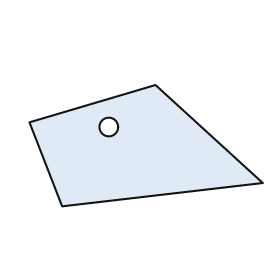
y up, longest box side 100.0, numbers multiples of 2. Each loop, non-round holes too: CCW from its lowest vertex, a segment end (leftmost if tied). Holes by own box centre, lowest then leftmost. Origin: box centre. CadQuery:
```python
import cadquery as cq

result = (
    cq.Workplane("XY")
    .moveTo(-36.0, -26.0)
    .lineTo(50.0, -16.0)
    .lineTo(4.0, 26.0)
    .lineTo(-50.0, 10.0)
    .close()
    .moveTo(-16.0, 8.0)
    .circle(4.0)
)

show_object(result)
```